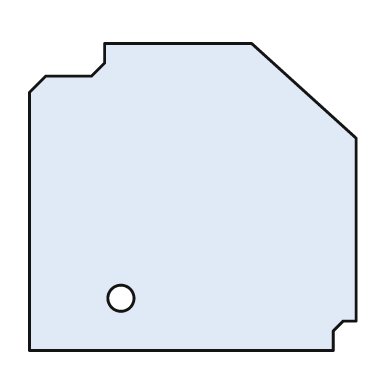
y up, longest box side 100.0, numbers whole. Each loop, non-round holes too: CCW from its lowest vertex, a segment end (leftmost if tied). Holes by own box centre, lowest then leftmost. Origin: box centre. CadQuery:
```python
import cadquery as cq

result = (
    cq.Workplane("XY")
    .moveTo(-50.0, -47.0)
    .lineTo(43.0, -47.0)
    .lineTo(43.0, -41.0)
    .lineTo(46.0, -38.0)
    .lineTo(50.0, -38.0)
    .lineTo(50.0, 18.0)
    .lineTo(18.0, 47.0)
    .lineTo(-27.0, 47.0)
    .lineTo(-27.0, 41.0)
    .lineTo(-31.0, 37.0)
    .lineTo(-45.0, 37.0)
    .lineTo(-50.0, 32.0)
    .close()
    .moveTo(-22.0, -31.0)
    .circle(4.0)
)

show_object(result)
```